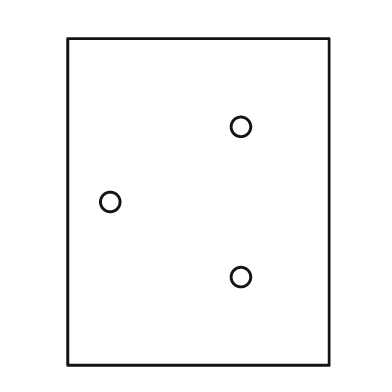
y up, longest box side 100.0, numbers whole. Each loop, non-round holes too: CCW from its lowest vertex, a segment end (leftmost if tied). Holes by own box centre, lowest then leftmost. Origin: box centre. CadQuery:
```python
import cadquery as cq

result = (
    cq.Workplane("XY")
    .moveTo(-40.0, -50.0)
    .lineTo(40.0, -50.0)
    .lineTo(40.0, 50.0)
    .lineTo(-40.0, 50.0)
    .close()
    .moveTo(13.0, -23.0)
    .circle(3.0)
    .moveTo(-27.0, 0.0)
    .circle(3.0)
    .moveTo(13.0, 23.0)
    .circle(3.0)
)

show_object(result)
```